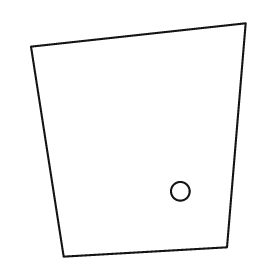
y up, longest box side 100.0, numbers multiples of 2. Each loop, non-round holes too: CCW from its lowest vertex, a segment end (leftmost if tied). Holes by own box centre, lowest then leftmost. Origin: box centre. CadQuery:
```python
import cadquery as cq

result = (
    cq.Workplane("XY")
    .moveTo(-32.0, -50.0)
    .lineTo(38.0, -46.0)
    .lineTo(46.0, 50.0)
    .lineTo(-46.0, 40.0)
    .close()
    .moveTo(18.0, -22.0)
    .circle(4.0)
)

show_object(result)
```